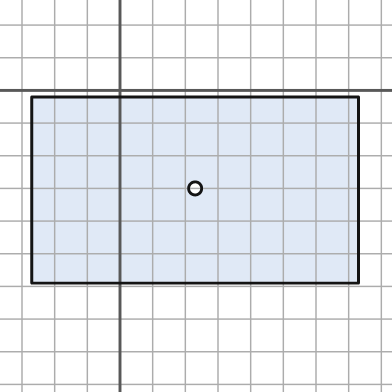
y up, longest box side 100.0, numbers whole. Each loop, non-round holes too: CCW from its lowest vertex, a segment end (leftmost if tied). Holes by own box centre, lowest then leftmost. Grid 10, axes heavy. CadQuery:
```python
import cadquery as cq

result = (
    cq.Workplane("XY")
    .moveTo(-27.0, -59.0)
    .lineTo(73.0, -59.0)
    .lineTo(73.0, -2.0)
    .lineTo(-27.0, -2.0)
    .close()
    .moveTo(23.0, -30.0)
    .circle(2.0)
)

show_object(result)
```